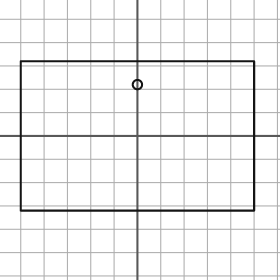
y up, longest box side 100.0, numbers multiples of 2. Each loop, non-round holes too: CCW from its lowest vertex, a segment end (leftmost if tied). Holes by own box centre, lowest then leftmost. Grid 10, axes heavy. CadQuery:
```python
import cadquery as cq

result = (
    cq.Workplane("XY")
    .moveTo(-50.0, -32.0)
    .lineTo(50.0, -32.0)
    .lineTo(50.0, 32.0)
    .lineTo(-50.0, 32.0)
    .close()
    .moveTo(0.0, 22.0)
    .circle(2.0)
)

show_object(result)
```